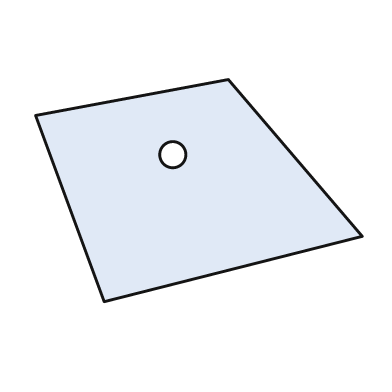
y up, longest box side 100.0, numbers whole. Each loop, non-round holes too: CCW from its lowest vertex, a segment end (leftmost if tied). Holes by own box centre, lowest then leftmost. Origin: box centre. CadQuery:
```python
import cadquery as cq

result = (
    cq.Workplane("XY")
    .moveTo(-29.0, -34.0)
    .lineTo(50.0, -14.0)
    .lineTo(9.0, 34.0)
    .lineTo(-50.0, 23.0)
    .close()
    .moveTo(-8.0, 11.0)
    .circle(4.0)
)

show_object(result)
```